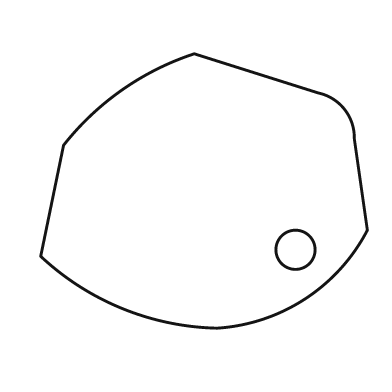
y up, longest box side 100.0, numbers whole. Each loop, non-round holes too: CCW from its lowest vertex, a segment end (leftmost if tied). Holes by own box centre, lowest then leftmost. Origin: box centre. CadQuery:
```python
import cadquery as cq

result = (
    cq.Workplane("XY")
    .moveTo(4.0, -42.0)
    .threePointArc((31.0, -33.0), (50.0, -12.0))
    .lineTo(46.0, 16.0)
    .threePointArc((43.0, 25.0), (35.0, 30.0))
    .lineTo(-3.0, 42.0)
    .threePointArc((-25.0, 31.0), (-43.0, 14.0))
    .lineTo(-50.0, -20.0)
    .threePointArc((-25.0, -36.0), (4.0, -42.0))
    .close()
    .moveTo(28.0, -18.0)
    .circle(6.0)
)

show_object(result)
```